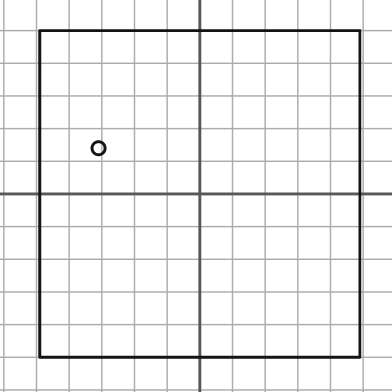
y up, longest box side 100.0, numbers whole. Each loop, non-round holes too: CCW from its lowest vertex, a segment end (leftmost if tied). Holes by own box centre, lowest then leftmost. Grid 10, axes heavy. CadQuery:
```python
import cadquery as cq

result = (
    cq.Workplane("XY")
    .moveTo(-49.0, -50.0)
    .lineTo(49.0, -50.0)
    .lineTo(49.0, 50.0)
    .lineTo(-49.0, 50.0)
    .close()
    .moveTo(-31.0, 14.0)
    .circle(2.0)
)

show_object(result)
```